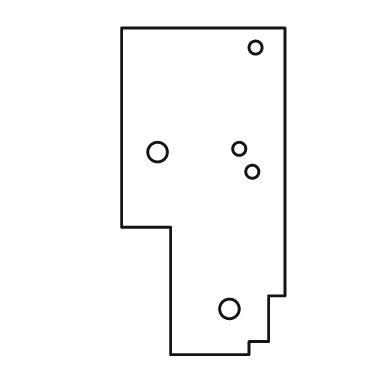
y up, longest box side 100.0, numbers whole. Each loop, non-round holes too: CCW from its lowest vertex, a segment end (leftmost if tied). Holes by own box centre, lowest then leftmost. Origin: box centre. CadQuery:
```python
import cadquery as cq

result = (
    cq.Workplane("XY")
    .moveTo(-10.0, -50.0)
    .lineTo(14.0, -50.0)
    .lineTo(14.0, -46.0)
    .lineTo(20.0, -46.0)
    .lineTo(20.0, -32.0)
    .lineTo(25.0, -32.0)
    .lineTo(25.0, 50.0)
    .lineTo(-25.0, 50.0)
    .lineTo(-25.0, -11.0)
    .lineTo(-10.0, -11.0)
    .close()
    .moveTo(8.0, -36.0)
    .circle(3.0)
    .moveTo(15.0, 6.0)
    .circle(2.0)
    .moveTo(-14.0, 12.0)
    .circle(3.0)
    .moveTo(11.0, 13.0)
    .circle(2.0)
    .moveTo(16.0, 44.0)
    .circle(2.0)
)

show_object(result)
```